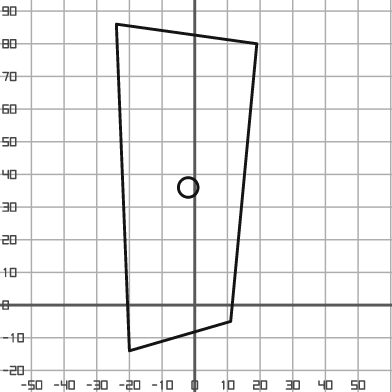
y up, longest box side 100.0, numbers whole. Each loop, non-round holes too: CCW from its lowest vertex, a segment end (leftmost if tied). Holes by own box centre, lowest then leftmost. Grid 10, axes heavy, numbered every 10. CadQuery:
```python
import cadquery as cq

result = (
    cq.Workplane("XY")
    .moveTo(-20.0, -14.0)
    .lineTo(11.0, -5.0)
    .lineTo(19.0, 80.0)
    .lineTo(-24.0, 86.0)
    .close()
    .moveTo(-2.0, 36.0)
    .circle(3.0)
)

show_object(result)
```